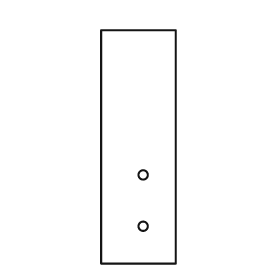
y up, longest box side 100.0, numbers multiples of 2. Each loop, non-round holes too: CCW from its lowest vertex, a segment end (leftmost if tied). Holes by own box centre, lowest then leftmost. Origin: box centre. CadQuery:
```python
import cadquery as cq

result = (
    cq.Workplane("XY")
    .moveTo(-16.0, -50.0)
    .lineTo(16.0, -50.0)
    .lineTo(16.0, 50.0)
    .lineTo(-16.0, 50.0)
    .close()
    .moveTo(2.0, -34.0)
    .circle(2.0)
    .moveTo(2.0, -12.0)
    .circle(2.0)
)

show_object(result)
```